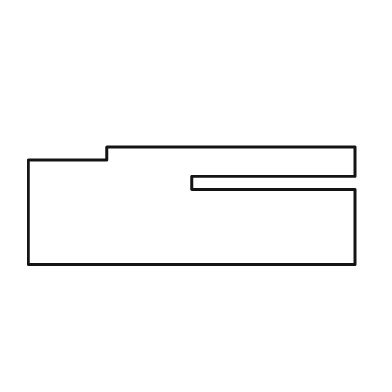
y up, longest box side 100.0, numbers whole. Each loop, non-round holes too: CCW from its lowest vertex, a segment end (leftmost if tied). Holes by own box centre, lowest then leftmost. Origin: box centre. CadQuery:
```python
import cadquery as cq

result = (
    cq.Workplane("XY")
    .moveTo(-50.0, -18.0)
    .lineTo(50.0, -18.0)
    .lineTo(50.0, 5.0)
    .lineTo(0.0, 5.0)
    .lineTo(0.0, 9.0)
    .lineTo(50.0, 9.0)
    .lineTo(50.0, 18.0)
    .lineTo(-26.0, 18.0)
    .lineTo(-26.0, 14.0)
    .lineTo(-50.0, 14.0)
    .close()
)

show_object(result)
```